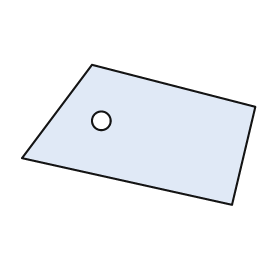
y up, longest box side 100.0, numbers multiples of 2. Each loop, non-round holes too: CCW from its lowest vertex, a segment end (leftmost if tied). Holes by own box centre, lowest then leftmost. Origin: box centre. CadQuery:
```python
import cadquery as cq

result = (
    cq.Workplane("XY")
    .moveTo(40.0, -30.0)
    .lineTo(50.0, 12.0)
    .lineTo(-20.0, 30.0)
    .lineTo(-50.0, -10.0)
    .close()
    .moveTo(-16.0, 6.0)
    .circle(4.0)
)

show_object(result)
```